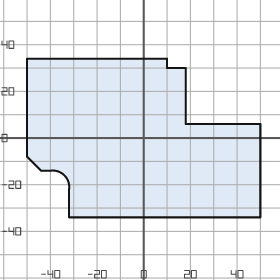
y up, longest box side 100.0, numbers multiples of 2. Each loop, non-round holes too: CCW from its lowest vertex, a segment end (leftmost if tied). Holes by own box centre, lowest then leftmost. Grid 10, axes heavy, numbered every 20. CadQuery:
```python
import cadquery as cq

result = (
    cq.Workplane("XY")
    .moveTo(-32.0, -34.0)
    .lineTo(50.0, -34.0)
    .lineTo(50.0, 6.0)
    .lineTo(18.0, 6.0)
    .lineTo(18.0, 30.0)
    .lineTo(10.0, 30.0)
    .lineTo(10.0, 34.0)
    .lineTo(-50.0, 34.0)
    .lineTo(-50.0, -8.0)
    .lineTo(-44.0, -14.0)
    .lineTo(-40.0, -14.0)
    .threePointArc((-34.0, -16.0), (-32.0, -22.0))
    .close()
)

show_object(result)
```